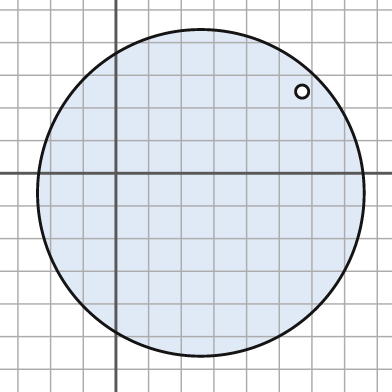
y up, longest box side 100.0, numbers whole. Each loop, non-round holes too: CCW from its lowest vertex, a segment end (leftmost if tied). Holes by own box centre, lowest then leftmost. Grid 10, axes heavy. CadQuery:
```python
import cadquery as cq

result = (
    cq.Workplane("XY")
    .moveTo(26.0, -6.0)
    .circle(50.0)
    .moveTo(57.0, 25.0)
    .circle(2.0)
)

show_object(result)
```